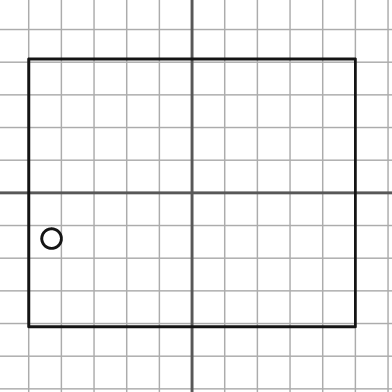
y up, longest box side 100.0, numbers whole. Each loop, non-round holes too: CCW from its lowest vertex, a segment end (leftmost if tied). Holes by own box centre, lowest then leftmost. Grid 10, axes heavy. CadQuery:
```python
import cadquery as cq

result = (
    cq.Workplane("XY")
    .moveTo(-50.0, -41.0)
    .lineTo(50.0, -41.0)
    .lineTo(50.0, 41.0)
    .lineTo(-50.0, 41.0)
    .close()
    .moveTo(-43.0, -14.0)
    .circle(3.0)
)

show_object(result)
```